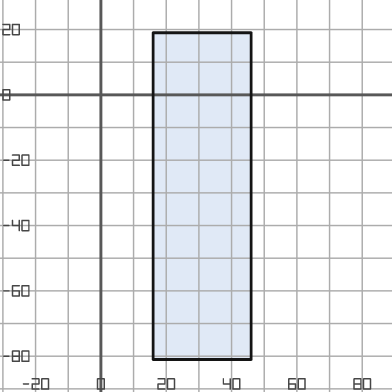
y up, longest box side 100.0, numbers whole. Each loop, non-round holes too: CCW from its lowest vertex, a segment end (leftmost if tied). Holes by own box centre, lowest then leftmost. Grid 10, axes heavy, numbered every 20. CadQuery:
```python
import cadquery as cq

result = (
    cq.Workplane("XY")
    .moveTo(16.0, -81.0)
    .lineTo(46.0, -81.0)
    .lineTo(46.0, 19.0)
    .lineTo(16.0, 19.0)
    .close()
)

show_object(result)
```